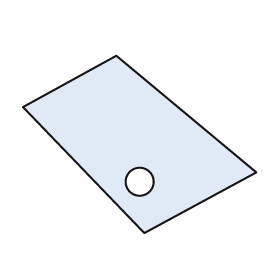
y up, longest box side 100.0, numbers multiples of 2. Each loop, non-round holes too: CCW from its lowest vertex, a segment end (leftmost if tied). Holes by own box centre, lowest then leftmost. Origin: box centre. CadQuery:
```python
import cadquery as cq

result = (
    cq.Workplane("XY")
    .moveTo(2.0, -38.0)
    .lineTo(50.0, -12.0)
    .lineTo(-10.0, 38.0)
    .lineTo(-50.0, 16.0)
    .close()
    .moveTo(0.0, -16.0)
    .circle(6.0)
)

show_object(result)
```